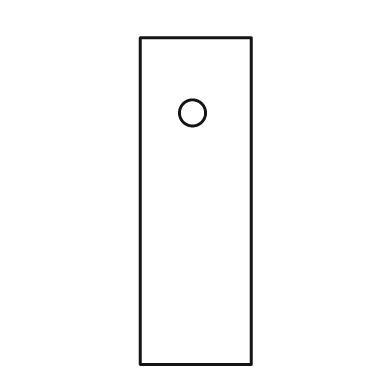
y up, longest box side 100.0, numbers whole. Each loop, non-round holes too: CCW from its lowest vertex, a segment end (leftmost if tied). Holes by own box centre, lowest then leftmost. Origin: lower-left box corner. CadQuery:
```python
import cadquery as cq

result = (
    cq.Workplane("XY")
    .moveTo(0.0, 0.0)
    .lineTo(34.0, 0.0)
    .lineTo(34.0, 100.0)
    .lineTo(0.0, 100.0)
    .close()
    .moveTo(16.0, 77.0)
    .circle(4.0)
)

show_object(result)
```